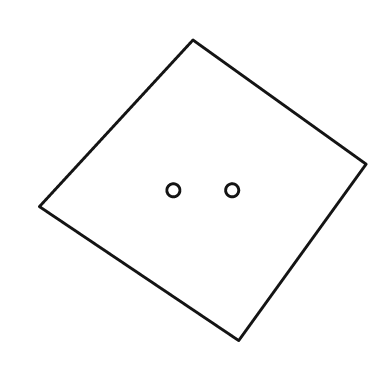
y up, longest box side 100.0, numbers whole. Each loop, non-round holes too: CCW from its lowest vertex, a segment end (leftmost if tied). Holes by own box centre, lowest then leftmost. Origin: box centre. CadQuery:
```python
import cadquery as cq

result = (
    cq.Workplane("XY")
    .moveTo(11.0, -46.0)
    .lineTo(50.0, 8.0)
    .lineTo(-3.0, 46.0)
    .lineTo(-50.0, -5.0)
    .close()
    .moveTo(-9.0, 0.0)
    .circle(2.0)
    .moveTo(9.0, 0.0)
    .circle(2.0)
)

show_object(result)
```